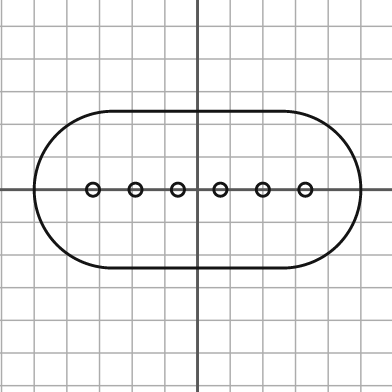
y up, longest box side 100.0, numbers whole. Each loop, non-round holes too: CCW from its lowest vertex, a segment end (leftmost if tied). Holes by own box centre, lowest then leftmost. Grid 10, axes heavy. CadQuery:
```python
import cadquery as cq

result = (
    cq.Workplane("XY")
    .moveTo(-26.0, -24.0)
    .lineTo(26.0, -24.0)
    .threePointArc((50.0, 0.0), (26.0, 24.0))
    .lineTo(-26.0, 24.0)
    .threePointArc((-50.0, 0.0), (-26.0, -24.0))
    .close()
    .moveTo(-32.0, 0.0)
    .circle(2.0)
    .moveTo(-19.0, 0.0)
    .circle(2.0)
    .moveTo(-6.0, 0.0)
    .circle(2.0)
    .moveTo(7.0, 0.0)
    .circle(2.0)
    .moveTo(20.0, 0.0)
    .circle(2.0)
    .moveTo(33.0, 0.0)
    .circle(2.0)
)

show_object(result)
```